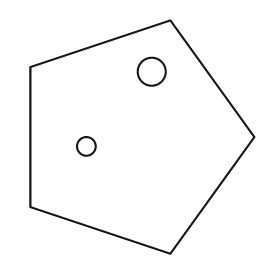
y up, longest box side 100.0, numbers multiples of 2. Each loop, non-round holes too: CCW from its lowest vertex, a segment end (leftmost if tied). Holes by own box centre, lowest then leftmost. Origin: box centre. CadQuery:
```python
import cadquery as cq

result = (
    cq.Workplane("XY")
    .moveTo(12.0, -50.0)
    .lineTo(48.0, 0.0)
    .lineTo(12.0, 50.0)
    .lineTo(-48.0, 30.0)
    .lineTo(-48.0, -30.0)
    .close()
    .moveTo(-24.0, -4.0)
    .circle(4.0)
    .moveTo(4.0, 28.0)
    .circle(6.0)
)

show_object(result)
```